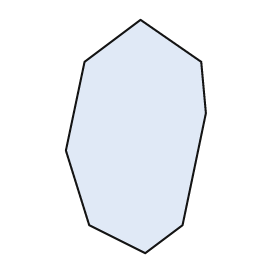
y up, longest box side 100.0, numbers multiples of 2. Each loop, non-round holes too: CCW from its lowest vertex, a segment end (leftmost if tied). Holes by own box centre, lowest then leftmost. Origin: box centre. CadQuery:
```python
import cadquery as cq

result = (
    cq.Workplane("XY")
    .moveTo(4.0, -50.0)
    .lineTo(20.0, -38.0)
    .lineTo(30.0, 10.0)
    .lineTo(28.0, 32.0)
    .lineTo(2.0, 50.0)
    .lineTo(-22.0, 32.0)
    .lineTo(-30.0, -6.0)
    .lineTo(-20.0, -38.0)
    .close()
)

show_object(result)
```